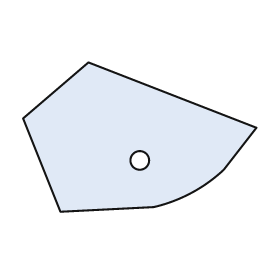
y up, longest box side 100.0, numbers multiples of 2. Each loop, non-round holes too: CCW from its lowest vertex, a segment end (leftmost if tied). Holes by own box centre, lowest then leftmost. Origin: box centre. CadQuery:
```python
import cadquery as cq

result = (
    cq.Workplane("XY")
    .moveTo(-34.0, -32.0)
    .lineTo(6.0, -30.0)
    .threePointArc((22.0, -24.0), (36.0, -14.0))
    .lineTo(50.0, 4.0)
    .lineTo(-22.0, 32.0)
    .lineTo(-50.0, 8.0)
    .close()
    .moveTo(0.0, -10.0)
    .circle(4.0)
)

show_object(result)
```